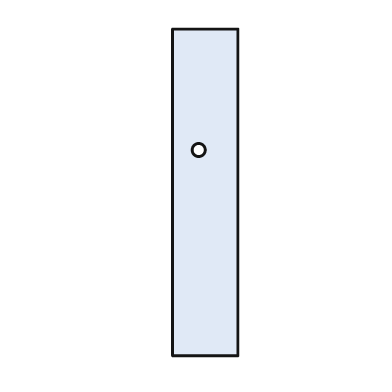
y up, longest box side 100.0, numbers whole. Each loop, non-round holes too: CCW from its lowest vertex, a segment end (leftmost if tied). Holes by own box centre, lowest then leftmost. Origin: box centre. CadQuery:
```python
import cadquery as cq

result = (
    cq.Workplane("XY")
    .moveTo(-10.0, -50.0)
    .lineTo(10.0, -50.0)
    .lineTo(10.0, 50.0)
    .lineTo(-10.0, 50.0)
    .close()
    .moveTo(-2.0, 13.0)
    .circle(2.0)
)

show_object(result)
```